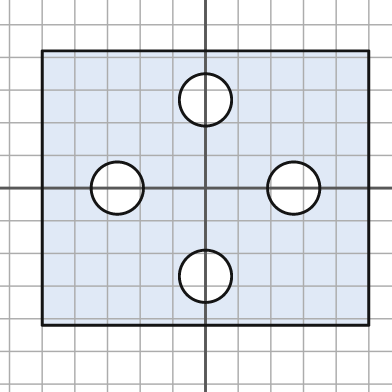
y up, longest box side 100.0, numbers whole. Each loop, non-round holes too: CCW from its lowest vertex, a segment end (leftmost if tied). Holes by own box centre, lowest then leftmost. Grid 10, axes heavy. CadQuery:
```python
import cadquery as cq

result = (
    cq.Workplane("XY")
    .moveTo(-50.0, -42.0)
    .lineTo(50.0, -42.0)
    .lineTo(50.0, 42.0)
    .lineTo(-50.0, 42.0)
    .close()
    .moveTo(0.0, -27.0)
    .circle(8.0)
    .moveTo(-27.0, 0.0)
    .circle(8.0)
    .moveTo(27.0, 0.0)
    .circle(8.0)
    .moveTo(0.0, 27.0)
    .circle(8.0)
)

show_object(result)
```